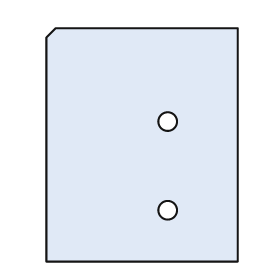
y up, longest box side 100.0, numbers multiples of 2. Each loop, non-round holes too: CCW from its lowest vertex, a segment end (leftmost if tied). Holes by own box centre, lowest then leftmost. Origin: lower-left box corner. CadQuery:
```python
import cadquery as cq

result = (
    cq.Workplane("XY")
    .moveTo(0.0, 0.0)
    .lineTo(82.0, 0.0)
    .lineTo(82.0, 100.0)
    .lineTo(4.0, 100.0)
    .lineTo(0.0, 96.0)
    .close()
    .moveTo(52.0, 22.0)
    .circle(4.0)
    .moveTo(52.0, 60.0)
    .circle(4.0)
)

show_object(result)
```